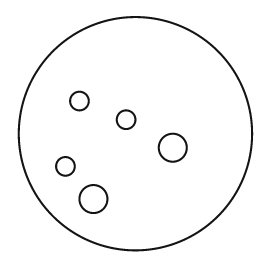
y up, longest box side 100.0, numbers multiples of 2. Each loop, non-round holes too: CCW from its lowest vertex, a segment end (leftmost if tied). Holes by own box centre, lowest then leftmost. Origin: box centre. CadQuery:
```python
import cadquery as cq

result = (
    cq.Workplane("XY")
    .moveTo(0.0, 0.0)
    .circle(50.0)
    .moveTo(-18.0, -28.0)
    .circle(6.0)
    .moveTo(-30.0, -14.0)
    .circle(4.0)
    .moveTo(16.0, -6.0)
    .circle(6.0)
    .moveTo(-4.0, 6.0)
    .circle(4.0)
    .moveTo(-24.0, 14.0)
    .circle(4.0)
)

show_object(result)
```